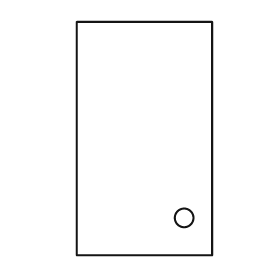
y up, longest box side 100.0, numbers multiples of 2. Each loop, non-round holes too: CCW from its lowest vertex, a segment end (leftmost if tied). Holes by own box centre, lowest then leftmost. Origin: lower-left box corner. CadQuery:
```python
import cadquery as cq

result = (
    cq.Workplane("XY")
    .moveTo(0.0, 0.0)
    .lineTo(58.0, 0.0)
    .lineTo(58.0, 100.0)
    .lineTo(0.0, 100.0)
    .close()
    .moveTo(46.0, 16.0)
    .circle(4.0)
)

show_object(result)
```